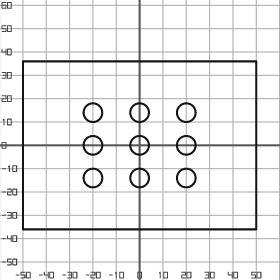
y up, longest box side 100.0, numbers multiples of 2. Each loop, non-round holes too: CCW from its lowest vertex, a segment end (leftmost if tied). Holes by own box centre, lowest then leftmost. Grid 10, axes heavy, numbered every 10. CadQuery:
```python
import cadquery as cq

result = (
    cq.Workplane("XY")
    .moveTo(-50.0, -36.0)
    .lineTo(50.0, -36.0)
    .lineTo(50.0, 36.0)
    .lineTo(-50.0, 36.0)
    .close()
    .moveTo(-20.0, -14.0)
    .circle(4.0)
    .moveTo(0.0, -14.0)
    .circle(4.0)
    .moveTo(20.0, -14.0)
    .circle(4.0)
    .moveTo(-20.0, 0.0)
    .circle(4.0)
    .moveTo(0.0, 0.0)
    .circle(4.0)
    .moveTo(20.0, 0.0)
    .circle(4.0)
    .moveTo(-20.0, 14.0)
    .circle(4.0)
    .moveTo(0.0, 14.0)
    .circle(4.0)
    .moveTo(20.0, 14.0)
    .circle(4.0)
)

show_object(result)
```